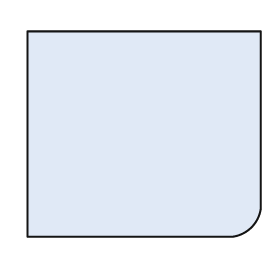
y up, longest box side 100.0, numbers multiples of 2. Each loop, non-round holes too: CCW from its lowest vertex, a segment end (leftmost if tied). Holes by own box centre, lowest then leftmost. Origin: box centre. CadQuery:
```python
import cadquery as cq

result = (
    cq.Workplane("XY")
    .moveTo(-50.0, -44.0)
    .lineTo(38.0, -44.0)
    .threePointArc((46.0, -40.0), (50.0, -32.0))
    .lineTo(50.0, 44.0)
    .lineTo(-50.0, 44.0)
    .close()
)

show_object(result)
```